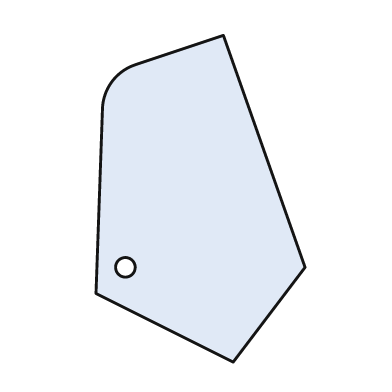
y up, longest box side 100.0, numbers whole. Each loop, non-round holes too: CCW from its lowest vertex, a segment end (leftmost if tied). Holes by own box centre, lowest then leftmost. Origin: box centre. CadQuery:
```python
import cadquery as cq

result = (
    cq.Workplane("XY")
    .moveTo(10.0, -50.0)
    .lineTo(32.0, -21.0)
    .lineTo(7.0, 50.0)
    .lineTo(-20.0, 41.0)
    .threePointArc((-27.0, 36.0), (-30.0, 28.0))
    .lineTo(-32.0, -29.0)
    .close()
    .moveTo(-23.0, -21.0)
    .circle(3.0)
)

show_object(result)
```